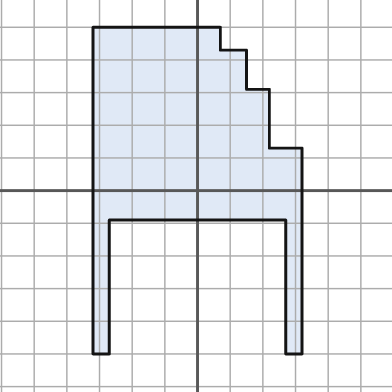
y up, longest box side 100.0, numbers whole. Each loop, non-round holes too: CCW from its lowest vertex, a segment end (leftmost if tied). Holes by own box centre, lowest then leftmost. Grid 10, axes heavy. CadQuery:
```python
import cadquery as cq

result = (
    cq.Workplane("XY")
    .moveTo(-32.0, -50.0)
    .lineTo(-27.0, -50.0)
    .lineTo(-27.0, -9.0)
    .lineTo(27.0, -9.0)
    .lineTo(27.0, -50.0)
    .lineTo(32.0, -50.0)
    .lineTo(32.0, 13.0)
    .lineTo(22.0, 13.0)
    .lineTo(22.0, 31.0)
    .lineTo(15.0, 31.0)
    .lineTo(15.0, 43.0)
    .lineTo(7.0, 43.0)
    .lineTo(7.0, 50.0)
    .lineTo(-32.0, 50.0)
    .close()
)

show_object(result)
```